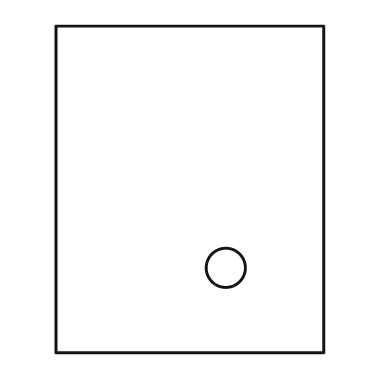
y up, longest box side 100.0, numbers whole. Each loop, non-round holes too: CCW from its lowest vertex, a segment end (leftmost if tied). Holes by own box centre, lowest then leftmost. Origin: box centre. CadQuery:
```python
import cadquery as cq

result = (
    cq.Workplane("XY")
    .moveTo(-41.0, -50.0)
    .lineTo(41.0, -50.0)
    .lineTo(41.0, 50.0)
    .lineTo(-41.0, 50.0)
    .close()
    .moveTo(11.0, -24.0)
    .circle(6.0)
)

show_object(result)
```